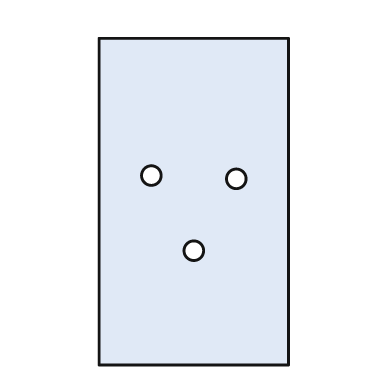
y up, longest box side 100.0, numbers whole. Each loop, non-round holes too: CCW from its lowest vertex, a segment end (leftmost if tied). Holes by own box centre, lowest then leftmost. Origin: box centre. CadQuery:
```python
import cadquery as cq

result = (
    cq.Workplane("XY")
    .moveTo(-29.0, -50.0)
    .lineTo(29.0, -50.0)
    .lineTo(29.0, 50.0)
    .lineTo(-29.0, 50.0)
    .close()
    .moveTo(0.0, -15.0)
    .circle(3.0)
    .moveTo(13.0, 7.0)
    .circle(3.0)
    .moveTo(-13.0, 8.0)
    .circle(3.0)
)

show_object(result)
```